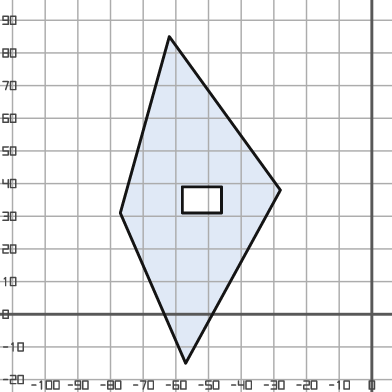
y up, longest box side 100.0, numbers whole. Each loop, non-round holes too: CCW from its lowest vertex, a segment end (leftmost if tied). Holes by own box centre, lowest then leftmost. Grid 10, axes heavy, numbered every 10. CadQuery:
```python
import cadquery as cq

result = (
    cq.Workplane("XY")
    .moveTo(-57.0, -15.0)
    .lineTo(-28.0, 38.0)
    .lineTo(-62.0, 85.0)
    .lineTo(-77.0, 31.0)
    .close()
    .moveTo(-58.0, 31.0)
    .lineTo(-46.0, 31.0)
    .lineTo(-46.0, 39.0)
    .lineTo(-58.0, 39.0)
    .close()
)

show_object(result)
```